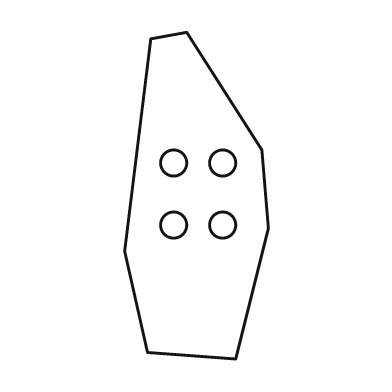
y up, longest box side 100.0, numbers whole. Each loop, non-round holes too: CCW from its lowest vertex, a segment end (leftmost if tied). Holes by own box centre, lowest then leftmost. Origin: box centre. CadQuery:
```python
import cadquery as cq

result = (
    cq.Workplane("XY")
    .moveTo(12.0, -50.0)
    .lineTo(22.0, -10.0)
    .lineTo(20.0, 14.0)
    .lineTo(-3.0, 50.0)
    .lineTo(-14.0, 48.0)
    .lineTo(-22.0, -17.0)
    .lineTo(-15.0, -48.0)
    .close()
    .moveTo(-7.0, -9.0)
    .circle(4.0)
    .moveTo(8.0, -9.0)
    .circle(4.0)
    .moveTo(-7.0, 10.0)
    .circle(4.0)
    .moveTo(8.0, 10.0)
    .circle(4.0)
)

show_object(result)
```